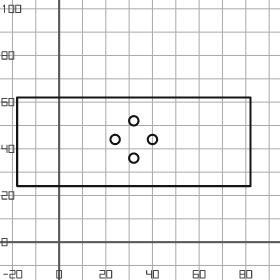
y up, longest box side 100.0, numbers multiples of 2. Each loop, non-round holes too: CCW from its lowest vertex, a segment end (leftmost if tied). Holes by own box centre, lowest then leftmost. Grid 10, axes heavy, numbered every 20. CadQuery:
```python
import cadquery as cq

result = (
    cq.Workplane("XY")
    .moveTo(-18.0, 24.0)
    .lineTo(82.0, 24.0)
    .lineTo(82.0, 62.0)
    .lineTo(-18.0, 62.0)
    .close()
    .moveTo(32.0, 36.0)
    .circle(2.0)
    .moveTo(24.0, 44.0)
    .circle(2.0)
    .moveTo(40.0, 44.0)
    .circle(2.0)
    .moveTo(32.0, 52.0)
    .circle(2.0)
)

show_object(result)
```